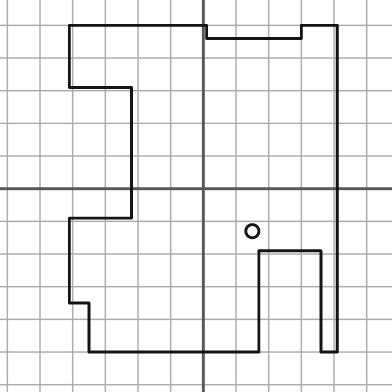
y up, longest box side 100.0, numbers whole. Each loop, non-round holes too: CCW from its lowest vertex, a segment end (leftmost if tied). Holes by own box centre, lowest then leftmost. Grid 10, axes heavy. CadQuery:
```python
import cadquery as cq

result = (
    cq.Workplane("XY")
    .moveTo(-35.0, -50.0)
    .lineTo(17.0, -50.0)
    .lineTo(17.0, -19.0)
    .lineTo(36.0, -19.0)
    .lineTo(36.0, -50.0)
    .lineTo(41.0, -50.0)
    .lineTo(41.0, 50.0)
    .lineTo(30.0, 50.0)
    .lineTo(30.0, 46.0)
    .lineTo(1.0, 46.0)
    .lineTo(1.0, 50.0)
    .lineTo(-41.0, 50.0)
    .lineTo(-41.0, 31.0)
    .lineTo(-22.0, 31.0)
    .lineTo(-22.0, -9.0)
    .lineTo(-41.0, -9.0)
    .lineTo(-41.0, -35.0)
    .lineTo(-35.0, -35.0)
    .close()
    .moveTo(15.0, -13.0)
    .circle(2.0)
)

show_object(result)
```